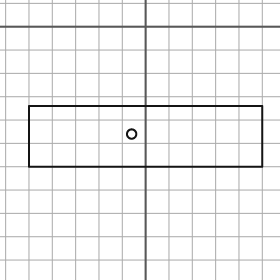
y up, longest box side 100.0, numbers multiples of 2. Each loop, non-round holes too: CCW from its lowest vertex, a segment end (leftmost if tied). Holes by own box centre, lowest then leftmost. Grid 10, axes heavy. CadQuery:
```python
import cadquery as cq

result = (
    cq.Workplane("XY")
    .moveTo(-50.0, -60.0)
    .lineTo(50.0, -60.0)
    .lineTo(50.0, -34.0)
    .lineTo(-50.0, -34.0)
    .close()
    .moveTo(-6.0, -46.0)
    .circle(2.0)
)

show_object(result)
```